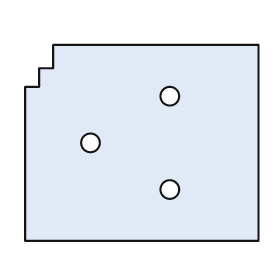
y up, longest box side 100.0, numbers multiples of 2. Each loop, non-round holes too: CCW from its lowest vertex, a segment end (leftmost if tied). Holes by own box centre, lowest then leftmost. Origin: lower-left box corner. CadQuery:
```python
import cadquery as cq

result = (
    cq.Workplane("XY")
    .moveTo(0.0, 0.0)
    .lineTo(100.0, 0.0)
    .lineTo(100.0, 84.0)
    .lineTo(12.0, 84.0)
    .lineTo(12.0, 74.0)
    .lineTo(6.0, 74.0)
    .lineTo(6.0, 66.0)
    .lineTo(0.0, 66.0)
    .close()
    .moveTo(62.0, 22.0)
    .circle(4.0)
    .moveTo(28.0, 42.0)
    .circle(4.0)
    .moveTo(62.0, 62.0)
    .circle(4.0)
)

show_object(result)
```